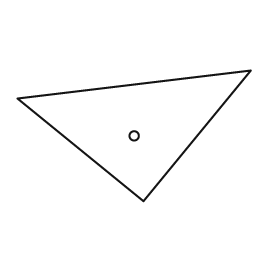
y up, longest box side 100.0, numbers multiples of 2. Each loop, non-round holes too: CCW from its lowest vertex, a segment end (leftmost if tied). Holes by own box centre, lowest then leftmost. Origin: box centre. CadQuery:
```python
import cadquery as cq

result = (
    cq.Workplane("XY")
    .moveTo(4.0, -28.0)
    .lineTo(50.0, 28.0)
    .lineTo(-50.0, 16.0)
    .close()
    .moveTo(0.0, 0.0)
    .circle(2.0)
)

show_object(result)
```